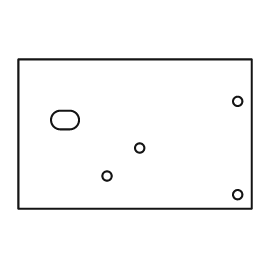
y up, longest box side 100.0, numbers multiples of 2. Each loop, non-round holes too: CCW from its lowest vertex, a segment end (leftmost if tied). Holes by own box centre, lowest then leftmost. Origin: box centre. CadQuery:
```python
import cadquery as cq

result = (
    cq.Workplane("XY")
    .moveTo(-50.0, -32.0)
    .lineTo(50.0, -32.0)
    .lineTo(50.0, 32.0)
    .lineTo(-50.0, 32.0)
    .close()
    .moveTo(44.0, -26.0)
    .circle(2.0)
    .moveTo(-12.0, -18.0)
    .circle(2.0)
    .moveTo(2.0, -6.0)
    .circle(2.0)
    .moveTo(-32.0, 2.0)
    .lineTo(-28.0, 2.0)
    .threePointArc((-24.0, 6.0), (-28.0, 10.0))
    .lineTo(-32.0, 10.0)
    .threePointArc((-36.0, 6.0), (-32.0, 2.0))
    .close()
    .moveTo(44.0, 14.0)
    .circle(2.0)
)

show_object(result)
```